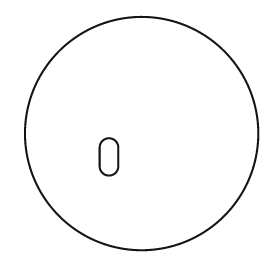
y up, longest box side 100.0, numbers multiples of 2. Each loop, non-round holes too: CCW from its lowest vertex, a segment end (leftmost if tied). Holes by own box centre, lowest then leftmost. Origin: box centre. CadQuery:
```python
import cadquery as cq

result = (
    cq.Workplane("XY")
    .moveTo(0.0, 0.0)
    .circle(50.0)
    .moveTo(-18.0, -14.0)
    .threePointArc((-14.0, -18.0), (-10.0, -14.0))
    .lineTo(-10.0, -6.0)
    .threePointArc((-14.0, -2.0), (-18.0, -6.0))
    .close()
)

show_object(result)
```